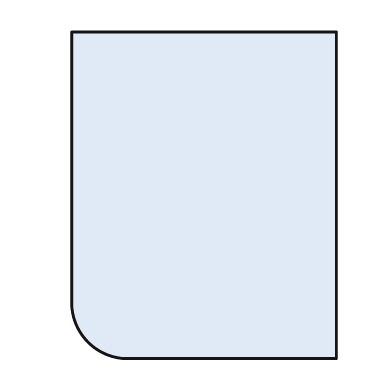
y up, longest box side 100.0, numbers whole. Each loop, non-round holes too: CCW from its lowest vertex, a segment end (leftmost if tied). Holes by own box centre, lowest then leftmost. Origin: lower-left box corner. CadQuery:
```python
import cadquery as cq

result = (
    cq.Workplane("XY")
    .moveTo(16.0, 0.0)
    .lineTo(81.0, 0.0)
    .lineTo(81.0, 100.0)
    .lineTo(0.0, 100.0)
    .lineTo(0.0, 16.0)
    .threePointArc((5.0, 5.0), (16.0, 0.0))
    .close()
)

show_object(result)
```